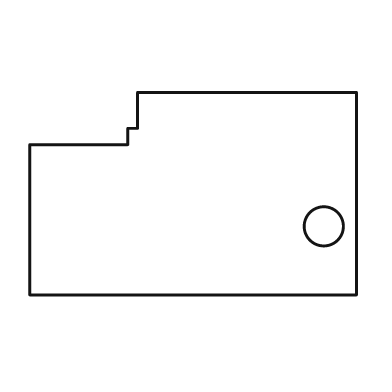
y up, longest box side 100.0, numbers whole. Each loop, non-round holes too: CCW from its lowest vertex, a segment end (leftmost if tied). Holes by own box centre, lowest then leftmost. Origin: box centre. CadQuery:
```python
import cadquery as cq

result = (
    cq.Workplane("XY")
    .moveTo(-50.0, -31.0)
    .lineTo(50.0, -31.0)
    .lineTo(50.0, 31.0)
    .lineTo(-17.0, 31.0)
    .lineTo(-17.0, 20.0)
    .lineTo(-20.0, 20.0)
    .lineTo(-20.0, 15.0)
    .lineTo(-50.0, 15.0)
    .close()
    .moveTo(40.0, -10.0)
    .circle(6.0)
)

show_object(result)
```